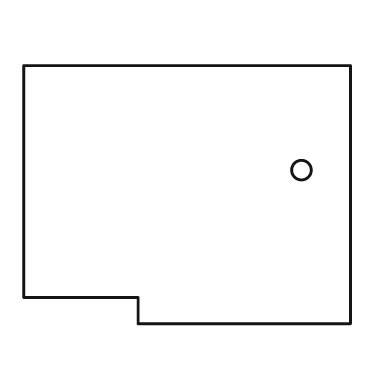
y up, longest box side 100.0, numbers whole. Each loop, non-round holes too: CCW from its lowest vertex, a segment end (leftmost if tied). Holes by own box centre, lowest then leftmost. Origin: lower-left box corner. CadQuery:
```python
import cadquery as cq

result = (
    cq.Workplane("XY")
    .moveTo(35.0, 0.0)
    .lineTo(100.0, 0.0)
    .lineTo(100.0, 79.0)
    .lineTo(0.0, 79.0)
    .lineTo(0.0, 8.0)
    .lineTo(35.0, 8.0)
    .close()
    .moveTo(85.0, 47.0)
    .circle(3.0)
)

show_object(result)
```